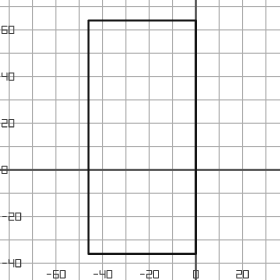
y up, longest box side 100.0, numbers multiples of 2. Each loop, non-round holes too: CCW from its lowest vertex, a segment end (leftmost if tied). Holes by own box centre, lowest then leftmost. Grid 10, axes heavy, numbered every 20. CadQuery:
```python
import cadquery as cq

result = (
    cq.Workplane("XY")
    .moveTo(-46.0, -36.0)
    .lineTo(0.0, -36.0)
    .lineTo(0.0, 64.0)
    .lineTo(-46.0, 64.0)
    .close()
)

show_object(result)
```